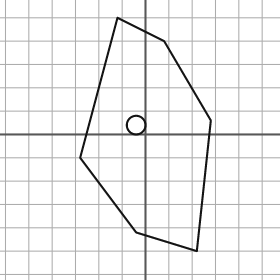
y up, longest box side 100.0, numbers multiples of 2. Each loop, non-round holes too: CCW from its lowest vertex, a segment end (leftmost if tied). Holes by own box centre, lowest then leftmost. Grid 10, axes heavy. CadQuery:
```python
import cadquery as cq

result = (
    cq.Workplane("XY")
    .moveTo(22.0, -50.0)
    .lineTo(28.0, 6.0)
    .lineTo(8.0, 40.0)
    .lineTo(-12.0, 50.0)
    .lineTo(-28.0, -10.0)
    .lineTo(-4.0, -42.0)
    .close()
    .moveTo(-4.0, 4.0)
    .circle(4.0)
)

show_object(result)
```